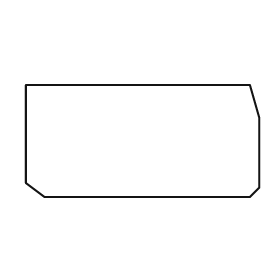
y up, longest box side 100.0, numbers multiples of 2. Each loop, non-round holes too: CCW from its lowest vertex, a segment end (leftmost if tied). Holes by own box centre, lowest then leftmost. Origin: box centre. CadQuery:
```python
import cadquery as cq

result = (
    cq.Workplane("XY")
    .moveTo(-42.0, -24.0)
    .lineTo(46.0, -24.0)
    .lineTo(50.0, -20.0)
    .lineTo(50.0, 10.0)
    .lineTo(46.0, 24.0)
    .lineTo(-50.0, 24.0)
    .lineTo(-50.0, -18.0)
    .close()
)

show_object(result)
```